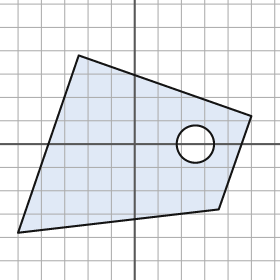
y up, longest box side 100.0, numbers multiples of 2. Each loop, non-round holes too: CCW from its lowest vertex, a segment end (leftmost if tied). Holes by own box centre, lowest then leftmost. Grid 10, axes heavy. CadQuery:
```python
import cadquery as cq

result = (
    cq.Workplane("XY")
    .moveTo(-50.0, -38.0)
    .lineTo(36.0, -28.0)
    .lineTo(50.0, 12.0)
    .lineTo(-24.0, 38.0)
    .close()
    .moveTo(26.0, 0.0)
    .circle(8.0)
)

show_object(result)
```